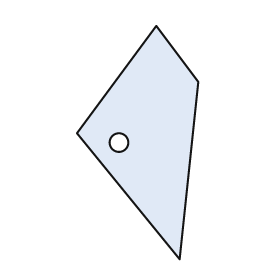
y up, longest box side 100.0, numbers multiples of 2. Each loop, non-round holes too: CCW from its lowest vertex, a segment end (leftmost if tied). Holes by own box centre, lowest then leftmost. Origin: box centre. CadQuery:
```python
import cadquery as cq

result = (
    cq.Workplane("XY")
    .moveTo(18.0, -50.0)
    .lineTo(26.0, 26.0)
    .lineTo(8.0, 50.0)
    .lineTo(-26.0, 4.0)
    .close()
    .moveTo(-8.0, 0.0)
    .circle(4.0)
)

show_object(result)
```